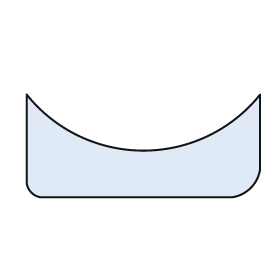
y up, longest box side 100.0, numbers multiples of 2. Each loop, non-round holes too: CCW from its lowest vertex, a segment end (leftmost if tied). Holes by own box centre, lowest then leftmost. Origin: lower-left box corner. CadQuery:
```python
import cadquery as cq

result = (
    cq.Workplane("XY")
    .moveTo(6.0, 0.0)
    .lineTo(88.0, 0.0)
    .threePointArc((96.0, 4.0), (100.0, 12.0))
    .lineTo(100.0, 44.0)
    .threePointArc((50.0, 20.0), (0.0, 44.0))
    .lineTo(0.0, 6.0)
    .threePointArc((2.0, 2.0), (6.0, 0.0))
    .close()
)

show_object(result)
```